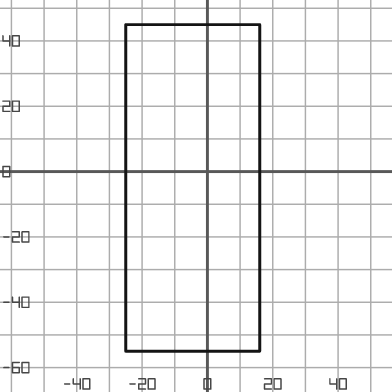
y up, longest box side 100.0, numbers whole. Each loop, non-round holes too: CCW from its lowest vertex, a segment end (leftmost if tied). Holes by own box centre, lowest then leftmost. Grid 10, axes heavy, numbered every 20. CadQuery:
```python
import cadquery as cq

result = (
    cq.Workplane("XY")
    .moveTo(-25.0, -55.0)
    .lineTo(16.0, -55.0)
    .lineTo(16.0, 45.0)
    .lineTo(-25.0, 45.0)
    .close()
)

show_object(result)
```